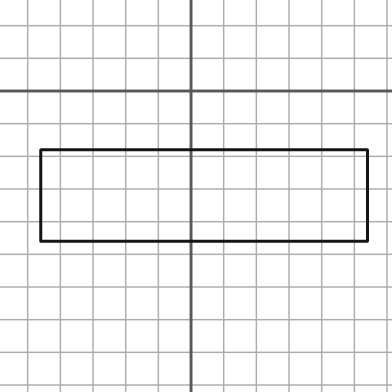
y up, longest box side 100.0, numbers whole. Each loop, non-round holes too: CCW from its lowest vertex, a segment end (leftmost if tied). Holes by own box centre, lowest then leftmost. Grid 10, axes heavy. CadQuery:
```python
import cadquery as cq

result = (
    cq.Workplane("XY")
    .moveTo(-46.0, -46.0)
    .lineTo(54.0, -46.0)
    .lineTo(54.0, -18.0)
    .lineTo(-46.0, -18.0)
    .close()
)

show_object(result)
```